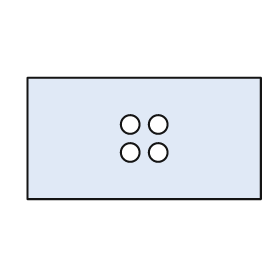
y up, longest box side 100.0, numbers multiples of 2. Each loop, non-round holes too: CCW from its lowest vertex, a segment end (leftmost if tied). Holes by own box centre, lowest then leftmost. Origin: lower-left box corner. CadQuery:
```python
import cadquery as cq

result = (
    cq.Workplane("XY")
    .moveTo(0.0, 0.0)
    .lineTo(100.0, 0.0)
    .lineTo(100.0, 52.0)
    .lineTo(0.0, 52.0)
    .close()
    .moveTo(44.0, 20.0)
    .circle(4.0)
    .moveTo(56.0, 20.0)
    .circle(4.0)
    .moveTo(44.0, 32.0)
    .circle(4.0)
    .moveTo(56.0, 32.0)
    .circle(4.0)
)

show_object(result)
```